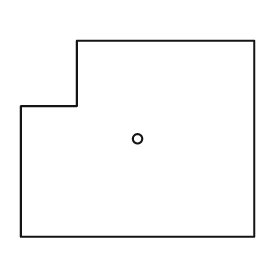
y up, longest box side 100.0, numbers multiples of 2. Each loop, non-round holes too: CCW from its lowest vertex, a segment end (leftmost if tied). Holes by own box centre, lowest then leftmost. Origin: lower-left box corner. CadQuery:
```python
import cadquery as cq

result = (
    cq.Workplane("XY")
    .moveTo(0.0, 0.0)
    .lineTo(100.0, 0.0)
    .lineTo(100.0, 84.0)
    .lineTo(24.0, 84.0)
    .lineTo(24.0, 56.0)
    .lineTo(0.0, 56.0)
    .close()
    .moveTo(50.0, 42.0)
    .circle(2.0)
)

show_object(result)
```